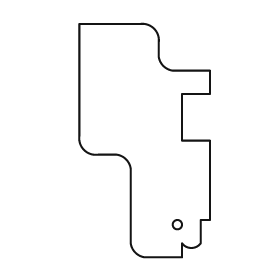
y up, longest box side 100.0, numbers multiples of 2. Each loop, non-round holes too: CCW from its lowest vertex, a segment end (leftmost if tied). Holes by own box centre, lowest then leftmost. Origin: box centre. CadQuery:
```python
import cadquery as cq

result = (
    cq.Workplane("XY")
    .moveTo(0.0, -50.0)
    .lineTo(16.0, -50.0)
    .lineTo(16.0, -44.0)
    .threePointArc((20.0, -46.0), (24.0, -44.0))
    .lineTo(24.0, -34.0)
    .lineTo(28.0, -34.0)
    .lineTo(28.0, 0.0)
    .lineTo(16.0, 0.0)
    .lineTo(16.0, 20.0)
    .lineTo(28.0, 20.0)
    .lineTo(28.0, 30.0)
    .lineTo(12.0, 30.0)
    .threePointArc((8.0, 32.0), (6.0, 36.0))
    .lineTo(6.0, 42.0)
    .threePointArc((4.0, 48.0), (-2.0, 50.0))
    .lineTo(-28.0, 50.0)
    .lineTo(-28.0, 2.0)
    .threePointArc((-26.0, -4.0), (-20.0, -6.0))
    .lineTo(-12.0, -6.0)
    .threePointArc((-8.0, -8.0), (-6.0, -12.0))
    .lineTo(-6.0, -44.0)
    .threePointArc((-4.0, -48.0), (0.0, -50.0))
    .close()
    .moveTo(14.0, -36.0)
    .circle(2.0)
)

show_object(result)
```